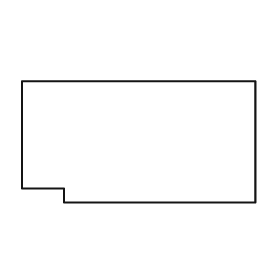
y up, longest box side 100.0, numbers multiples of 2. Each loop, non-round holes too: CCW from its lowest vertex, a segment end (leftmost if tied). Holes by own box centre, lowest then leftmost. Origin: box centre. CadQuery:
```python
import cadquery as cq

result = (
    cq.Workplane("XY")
    .moveTo(-32.0, -26.0)
    .lineTo(50.0, -26.0)
    .lineTo(50.0, 26.0)
    .lineTo(-50.0, 26.0)
    .lineTo(-50.0, -20.0)
    .lineTo(-32.0, -20.0)
    .close()
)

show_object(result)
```